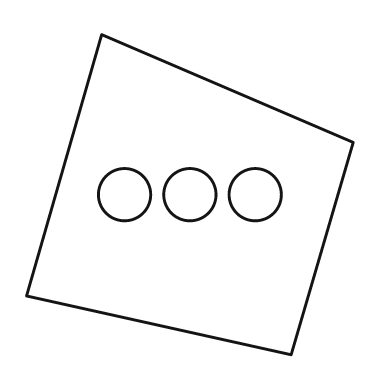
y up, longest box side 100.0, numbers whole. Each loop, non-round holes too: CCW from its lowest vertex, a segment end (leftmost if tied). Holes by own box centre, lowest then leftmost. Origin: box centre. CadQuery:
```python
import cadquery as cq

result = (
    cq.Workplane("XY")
    .moveTo(31.0, -49.0)
    .lineTo(50.0, 16.0)
    .lineTo(-27.0, 49.0)
    .lineTo(-50.0, -31.0)
    .close()
    .moveTo(-20.0, 0.0)
    .circle(8.0)
    .moveTo(0.0, 0.0)
    .circle(8.0)
    .moveTo(20.0, 0.0)
    .circle(8.0)
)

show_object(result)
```